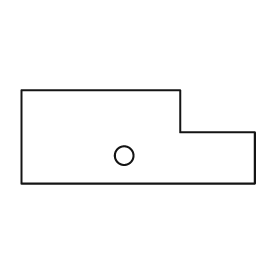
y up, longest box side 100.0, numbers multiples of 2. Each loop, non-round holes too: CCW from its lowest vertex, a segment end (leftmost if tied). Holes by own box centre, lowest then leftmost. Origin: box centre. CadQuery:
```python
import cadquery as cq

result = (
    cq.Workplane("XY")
    .moveTo(-50.0, -20.0)
    .lineTo(50.0, -20.0)
    .lineTo(50.0, 2.0)
    .lineTo(18.0, 2.0)
    .lineTo(18.0, 20.0)
    .lineTo(-50.0, 20.0)
    .close()
    .moveTo(-6.0, -8.0)
    .circle(4.0)
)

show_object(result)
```